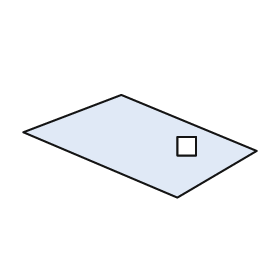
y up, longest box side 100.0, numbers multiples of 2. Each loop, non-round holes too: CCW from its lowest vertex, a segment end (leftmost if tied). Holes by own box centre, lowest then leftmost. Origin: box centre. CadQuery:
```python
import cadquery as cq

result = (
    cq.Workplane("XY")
    .moveTo(16.0, -22.0)
    .lineTo(50.0, -2.0)
    .lineTo(-8.0, 22.0)
    .lineTo(-50.0, 6.0)
    .close()
    .moveTo(16.0, -4.0)
    .lineTo(24.0, -4.0)
    .lineTo(24.0, 4.0)
    .lineTo(16.0, 4.0)
    .close()
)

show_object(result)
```